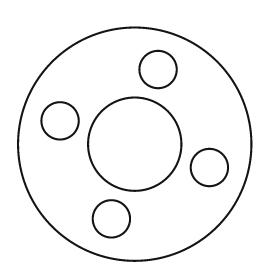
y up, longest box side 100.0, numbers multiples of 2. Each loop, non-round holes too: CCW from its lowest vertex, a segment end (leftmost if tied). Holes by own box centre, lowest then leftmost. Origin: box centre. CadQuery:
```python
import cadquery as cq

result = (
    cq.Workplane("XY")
    .moveTo(0.0, 0.0)
    .circle(50.0)
    .moveTo(-10.0, -32.0)
    .circle(8.0)
    .moveTo(32.0, -10.0)
    .circle(8.0)
    .moveTo(0.0, 0.0)
    .circle(20.0)
    .moveTo(-32.0, 10.0)
    .circle(8.0)
    .moveTo(10.0, 32.0)
    .circle(8.0)
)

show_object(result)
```